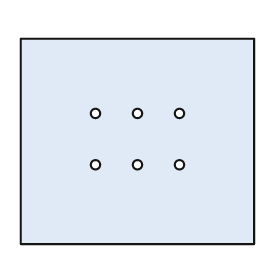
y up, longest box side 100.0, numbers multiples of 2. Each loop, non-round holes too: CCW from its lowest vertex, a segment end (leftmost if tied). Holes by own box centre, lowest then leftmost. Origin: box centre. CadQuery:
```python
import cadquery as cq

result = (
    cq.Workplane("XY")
    .moveTo(-50.0, -44.0)
    .lineTo(50.0, -44.0)
    .lineTo(50.0, 44.0)
    .lineTo(-50.0, 44.0)
    .close()
    .moveTo(-18.0, -10.0)
    .circle(2.0)
    .moveTo(0.0, -10.0)
    .circle(2.0)
    .moveTo(18.0, -10.0)
    .circle(2.0)
    .moveTo(-18.0, 12.0)
    .circle(2.0)
    .moveTo(0.0, 12.0)
    .circle(2.0)
    .moveTo(18.0, 12.0)
    .circle(2.0)
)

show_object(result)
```